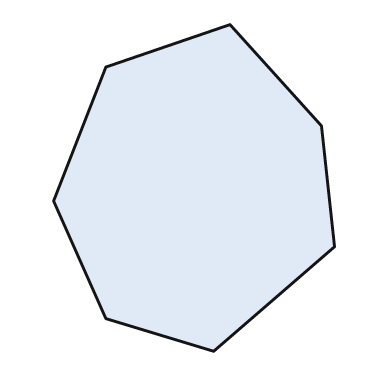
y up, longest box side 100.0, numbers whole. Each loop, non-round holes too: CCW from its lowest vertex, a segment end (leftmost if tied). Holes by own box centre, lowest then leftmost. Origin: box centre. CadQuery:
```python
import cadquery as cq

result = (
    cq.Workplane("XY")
    .moveTo(6.0, -50.0)
    .lineTo(43.0, -18.0)
    .lineTo(39.0, 19.0)
    .lineTo(11.0, 50.0)
    .lineTo(-27.0, 37.0)
    .lineTo(-43.0, -4.0)
    .lineTo(-27.0, -40.0)
    .close()
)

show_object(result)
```